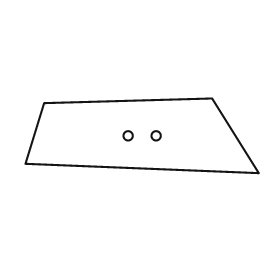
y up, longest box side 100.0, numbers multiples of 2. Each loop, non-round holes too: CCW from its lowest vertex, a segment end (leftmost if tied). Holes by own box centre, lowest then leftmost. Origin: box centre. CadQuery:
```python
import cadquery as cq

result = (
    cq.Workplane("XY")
    .moveTo(50.0, -16.0)
    .lineTo(30.0, 16.0)
    .lineTo(-42.0, 14.0)
    .lineTo(-50.0, -12.0)
    .close()
    .moveTo(-6.0, 0.0)
    .circle(2.0)
    .moveTo(6.0, 0.0)
    .circle(2.0)
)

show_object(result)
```